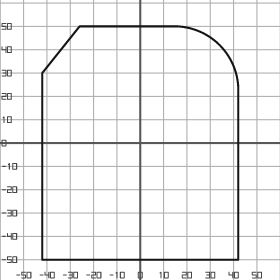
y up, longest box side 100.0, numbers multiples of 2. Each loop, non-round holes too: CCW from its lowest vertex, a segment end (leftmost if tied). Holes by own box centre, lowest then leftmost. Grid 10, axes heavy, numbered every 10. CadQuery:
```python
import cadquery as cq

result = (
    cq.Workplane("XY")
    .moveTo(-42.0, -50.0)
    .lineTo(42.0, -50.0)
    .lineTo(42.0, 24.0)
    .threePointArc((34.0, 42.0), (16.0, 50.0))
    .lineTo(-26.0, 50.0)
    .lineTo(-42.0, 30.0)
    .close()
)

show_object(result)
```